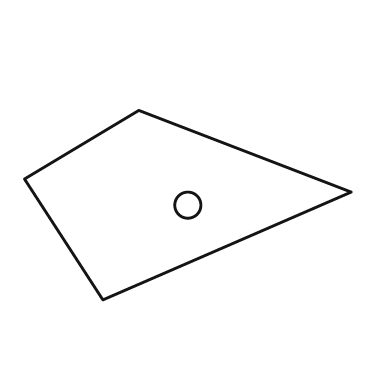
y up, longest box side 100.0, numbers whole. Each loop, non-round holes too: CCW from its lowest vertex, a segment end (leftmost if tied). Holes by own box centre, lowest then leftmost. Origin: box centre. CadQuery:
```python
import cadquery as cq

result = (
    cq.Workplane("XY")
    .moveTo(-26.0, -29.0)
    .lineTo(50.0, 4.0)
    .lineTo(-15.0, 29.0)
    .lineTo(-50.0, 8.0)
    .close()
    .moveTo(0.0, 0.0)
    .circle(4.0)
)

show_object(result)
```